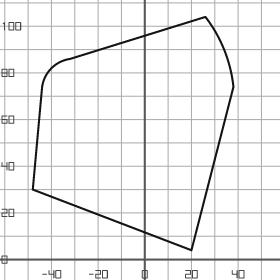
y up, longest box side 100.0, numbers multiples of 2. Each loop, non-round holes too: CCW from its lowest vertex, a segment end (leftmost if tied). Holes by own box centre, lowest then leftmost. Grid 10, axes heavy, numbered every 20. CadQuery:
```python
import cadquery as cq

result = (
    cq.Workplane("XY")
    .moveTo(20.0, 4.0)
    .lineTo(38.0, 74.0)
    .threePointArc((34.0, 90.0), (26.0, 104.0))
    .lineTo(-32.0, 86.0)
    .threePointArc((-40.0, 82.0), (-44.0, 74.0))
    .lineTo(-48.0, 30.0)
    .close()
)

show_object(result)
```